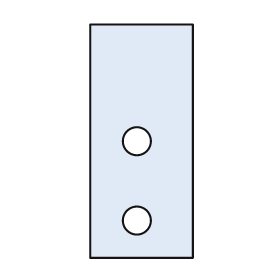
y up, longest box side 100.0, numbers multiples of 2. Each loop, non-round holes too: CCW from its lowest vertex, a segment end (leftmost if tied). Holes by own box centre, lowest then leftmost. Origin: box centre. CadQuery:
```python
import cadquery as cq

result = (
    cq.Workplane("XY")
    .moveTo(-22.0, -50.0)
    .lineTo(22.0, -50.0)
    .lineTo(22.0, 50.0)
    .lineTo(-22.0, 50.0)
    .close()
    .moveTo(-2.0, -34.0)
    .circle(6.0)
    .moveTo(-2.0, 0.0)
    .circle(6.0)
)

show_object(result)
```